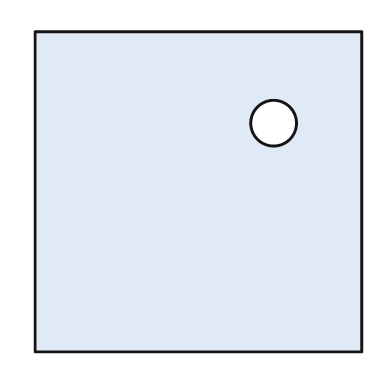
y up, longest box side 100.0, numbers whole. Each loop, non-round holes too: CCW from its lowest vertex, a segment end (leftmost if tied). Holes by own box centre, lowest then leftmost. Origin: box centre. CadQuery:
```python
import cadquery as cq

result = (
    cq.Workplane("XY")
    .moveTo(-50.0, -49.0)
    .lineTo(50.0, -49.0)
    .lineTo(50.0, 49.0)
    .lineTo(-50.0, 49.0)
    .close()
    .moveTo(23.0, 21.0)
    .circle(7.0)
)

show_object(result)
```